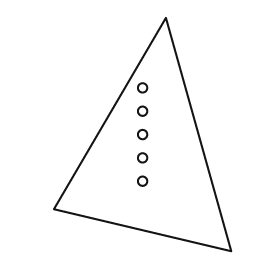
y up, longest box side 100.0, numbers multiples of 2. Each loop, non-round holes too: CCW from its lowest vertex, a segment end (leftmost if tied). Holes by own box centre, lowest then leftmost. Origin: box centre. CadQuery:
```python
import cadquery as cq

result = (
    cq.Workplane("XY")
    .moveTo(38.0, -50.0)
    .lineTo(10.0, 50.0)
    .lineTo(-38.0, -32.0)
    .close()
    .moveTo(0.0, -20.0)
    .circle(2.0)
    .moveTo(0.0, -10.0)
    .circle(2.0)
    .moveTo(0.0, 0.0)
    .circle(2.0)
    .moveTo(0.0, 10.0)
    .circle(2.0)
    .moveTo(0.0, 20.0)
    .circle(2.0)
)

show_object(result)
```